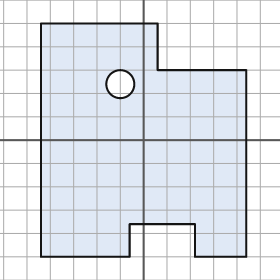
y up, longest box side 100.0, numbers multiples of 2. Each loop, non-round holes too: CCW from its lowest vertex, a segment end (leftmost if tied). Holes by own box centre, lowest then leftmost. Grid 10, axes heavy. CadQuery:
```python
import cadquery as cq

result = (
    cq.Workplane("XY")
    .moveTo(-44.0, -50.0)
    .lineTo(-6.0, -50.0)
    .lineTo(-6.0, -36.0)
    .lineTo(22.0, -36.0)
    .lineTo(22.0, -50.0)
    .lineTo(44.0, -50.0)
    .lineTo(44.0, 30.0)
    .lineTo(6.0, 30.0)
    .lineTo(6.0, 50.0)
    .lineTo(-44.0, 50.0)
    .close()
    .moveTo(-10.0, 24.0)
    .circle(6.0)
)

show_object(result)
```